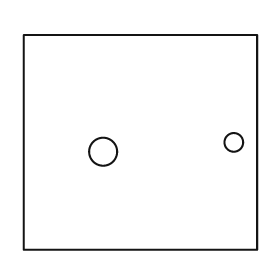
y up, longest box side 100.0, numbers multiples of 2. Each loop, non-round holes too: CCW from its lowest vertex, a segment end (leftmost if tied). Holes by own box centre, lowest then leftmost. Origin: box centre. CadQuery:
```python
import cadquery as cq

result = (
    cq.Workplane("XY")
    .moveTo(-50.0, -46.0)
    .lineTo(50.0, -46.0)
    .lineTo(50.0, 46.0)
    .lineTo(-50.0, 46.0)
    .close()
    .moveTo(-16.0, -4.0)
    .circle(6.0)
    .moveTo(40.0, 0.0)
    .circle(4.0)
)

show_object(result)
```